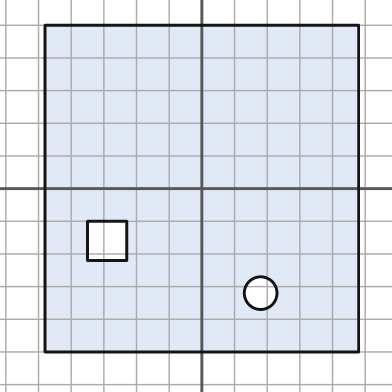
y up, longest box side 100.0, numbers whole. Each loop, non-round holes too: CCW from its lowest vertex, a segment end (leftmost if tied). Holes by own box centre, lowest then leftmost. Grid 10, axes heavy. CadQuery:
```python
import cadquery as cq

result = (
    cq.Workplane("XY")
    .moveTo(-48.0, -50.0)
    .lineTo(48.0, -50.0)
    .lineTo(48.0, 50.0)
    .lineTo(-48.0, 50.0)
    .close()
    .moveTo(18.0, -32.0)
    .circle(5.0)
    .moveTo(-35.0, -22.0)
    .lineTo(-23.0, -22.0)
    .lineTo(-23.0, -10.0)
    .lineTo(-35.0, -10.0)
    .close()
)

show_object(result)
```